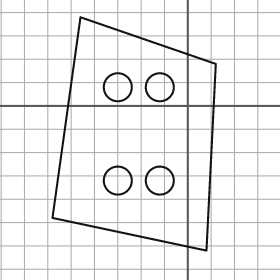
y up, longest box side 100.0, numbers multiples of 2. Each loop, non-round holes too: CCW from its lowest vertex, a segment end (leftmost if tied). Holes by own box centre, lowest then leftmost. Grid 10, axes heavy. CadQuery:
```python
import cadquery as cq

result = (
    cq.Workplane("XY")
    .moveTo(8.0, -62.0)
    .lineTo(12.0, 18.0)
    .lineTo(-46.0, 38.0)
    .lineTo(-58.0, -48.0)
    .close()
    .moveTo(-30.0, -32.0)
    .circle(6.0)
    .moveTo(-12.0, -32.0)
    .circle(6.0)
    .moveTo(-30.0, 8.0)
    .circle(6.0)
    .moveTo(-12.0, 8.0)
    .circle(6.0)
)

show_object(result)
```